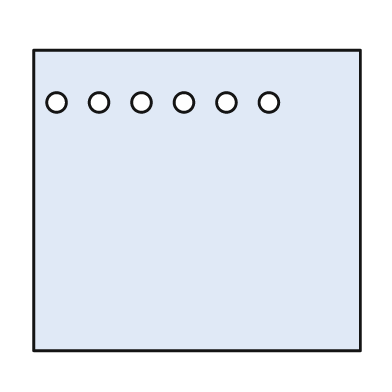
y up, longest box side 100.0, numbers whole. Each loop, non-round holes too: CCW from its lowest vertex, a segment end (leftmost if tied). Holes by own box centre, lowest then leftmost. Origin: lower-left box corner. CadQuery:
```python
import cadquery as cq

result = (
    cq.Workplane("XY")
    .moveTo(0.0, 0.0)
    .lineTo(100.0, 0.0)
    .lineTo(100.0, 92.0)
    .lineTo(0.0, 92.0)
    .close()
    .moveTo(7.0, 76.0)
    .circle(3.0)
    .moveTo(20.0, 76.0)
    .circle(3.0)
    .moveTo(33.0, 76.0)
    .circle(3.0)
    .moveTo(46.0, 76.0)
    .circle(3.0)
    .moveTo(59.0, 76.0)
    .circle(3.0)
    .moveTo(72.0, 76.0)
    .circle(3.0)
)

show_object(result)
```